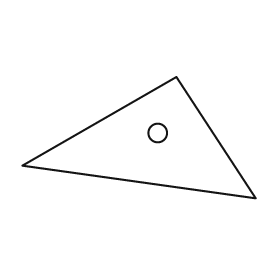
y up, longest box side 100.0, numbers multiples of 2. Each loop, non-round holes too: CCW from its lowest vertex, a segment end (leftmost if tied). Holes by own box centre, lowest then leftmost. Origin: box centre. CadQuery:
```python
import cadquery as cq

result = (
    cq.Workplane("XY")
    .moveTo(50.0, -26.0)
    .lineTo(16.0, 26.0)
    .lineTo(-50.0, -12.0)
    .close()
    .moveTo(8.0, 2.0)
    .circle(4.0)
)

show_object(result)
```